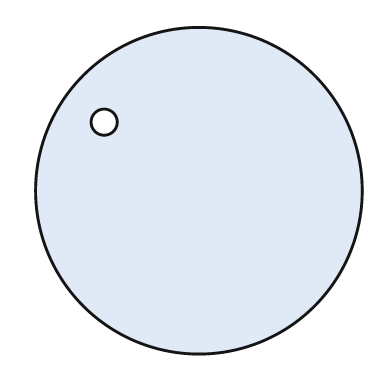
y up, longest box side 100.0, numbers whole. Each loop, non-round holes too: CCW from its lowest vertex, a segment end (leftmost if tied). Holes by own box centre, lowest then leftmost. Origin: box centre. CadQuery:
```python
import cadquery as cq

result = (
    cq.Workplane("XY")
    .moveTo(0.0, 0.0)
    .circle(50.0)
    .moveTo(-29.0, 21.0)
    .circle(4.0)
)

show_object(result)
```